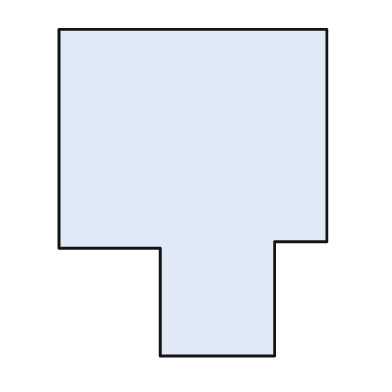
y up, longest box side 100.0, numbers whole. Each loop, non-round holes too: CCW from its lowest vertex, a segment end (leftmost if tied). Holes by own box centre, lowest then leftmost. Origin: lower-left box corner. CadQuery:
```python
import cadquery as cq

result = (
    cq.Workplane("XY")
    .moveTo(31.0, 0.0)
    .lineTo(66.0, 0.0)
    .lineTo(66.0, 35.0)
    .lineTo(82.0, 35.0)
    .lineTo(82.0, 100.0)
    .lineTo(0.0, 100.0)
    .lineTo(0.0, 33.0)
    .lineTo(31.0, 33.0)
    .close()
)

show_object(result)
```